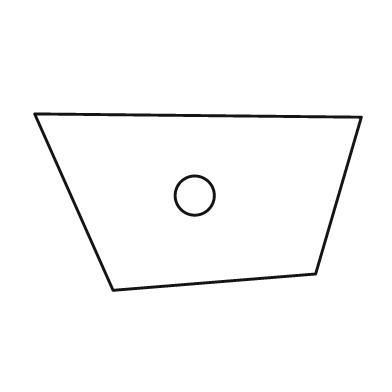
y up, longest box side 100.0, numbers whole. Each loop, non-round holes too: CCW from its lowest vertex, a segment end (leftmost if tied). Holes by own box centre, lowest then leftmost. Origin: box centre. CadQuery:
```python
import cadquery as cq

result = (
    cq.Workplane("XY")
    .moveTo(-26.0, -27.0)
    .lineTo(36.0, -22.0)
    .lineTo(50.0, 26.0)
    .lineTo(-50.0, 27.0)
    .close()
    .moveTo(-1.0, 2.0)
    .circle(6.0)
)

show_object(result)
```